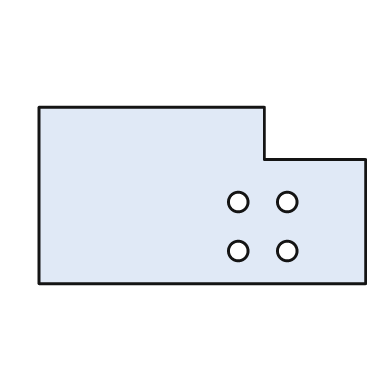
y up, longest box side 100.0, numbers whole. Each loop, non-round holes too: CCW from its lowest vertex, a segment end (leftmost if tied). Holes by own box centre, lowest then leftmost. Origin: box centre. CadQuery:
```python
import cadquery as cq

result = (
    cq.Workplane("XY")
    .moveTo(-50.0, -27.0)
    .lineTo(50.0, -27.0)
    .lineTo(50.0, 11.0)
    .lineTo(19.0, 11.0)
    .lineTo(19.0, 27.0)
    .lineTo(-50.0, 27.0)
    .close()
    .moveTo(11.0, -17.0)
    .circle(3.0)
    .moveTo(26.0, -17.0)
    .circle(3.0)
    .moveTo(11.0, -2.0)
    .circle(3.0)
    .moveTo(26.0, -2.0)
    .circle(3.0)
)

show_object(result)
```